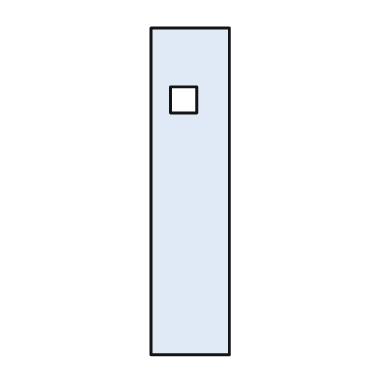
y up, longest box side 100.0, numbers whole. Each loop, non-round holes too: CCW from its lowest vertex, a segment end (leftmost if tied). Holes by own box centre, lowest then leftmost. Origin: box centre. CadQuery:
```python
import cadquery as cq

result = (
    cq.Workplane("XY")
    .moveTo(-12.0, -50.0)
    .lineTo(12.0, -50.0)
    .lineTo(12.0, 50.0)
    .lineTo(-12.0, 50.0)
    .close()
    .moveTo(-6.0, 24.0)
    .lineTo(2.0, 24.0)
    .lineTo(2.0, 32.0)
    .lineTo(-6.0, 32.0)
    .close()
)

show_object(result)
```